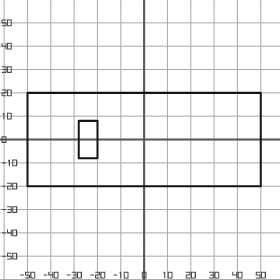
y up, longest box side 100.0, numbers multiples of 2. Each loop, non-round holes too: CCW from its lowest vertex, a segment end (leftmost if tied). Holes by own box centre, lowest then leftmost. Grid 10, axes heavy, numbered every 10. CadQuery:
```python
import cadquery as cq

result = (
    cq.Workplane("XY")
    .moveTo(-50.0, -20.0)
    .lineTo(50.0, -20.0)
    .lineTo(50.0, 20.0)
    .lineTo(-50.0, 20.0)
    .close()
    .moveTo(-28.0, -8.0)
    .lineTo(-20.0, -8.0)
    .lineTo(-20.0, 8.0)
    .lineTo(-28.0, 8.0)
    .close()
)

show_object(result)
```